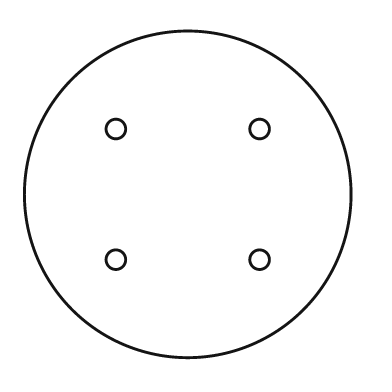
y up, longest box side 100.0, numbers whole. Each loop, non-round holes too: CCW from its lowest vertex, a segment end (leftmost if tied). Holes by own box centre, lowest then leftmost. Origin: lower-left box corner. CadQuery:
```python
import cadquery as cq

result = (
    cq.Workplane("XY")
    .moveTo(50.0, 50.0)
    .circle(50.0)
    .moveTo(28.0, 30.0)
    .circle(3.0)
    .moveTo(72.0, 30.0)
    .circle(3.0)
    .moveTo(28.0, 70.0)
    .circle(3.0)
    .moveTo(72.0, 70.0)
    .circle(3.0)
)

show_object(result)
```